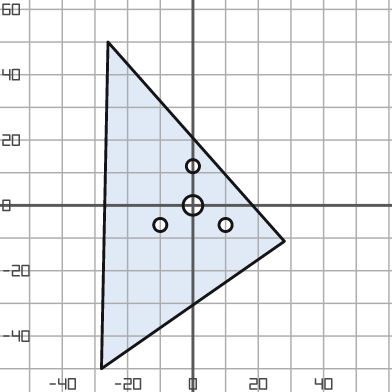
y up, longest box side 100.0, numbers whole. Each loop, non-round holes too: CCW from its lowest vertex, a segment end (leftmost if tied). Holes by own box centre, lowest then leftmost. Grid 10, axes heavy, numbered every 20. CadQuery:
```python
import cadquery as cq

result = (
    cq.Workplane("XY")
    .moveTo(-28.0, -50.0)
    .lineTo(28.0, -11.0)
    .lineTo(-26.0, 50.0)
    .close()
    .moveTo(-10.0, -6.0)
    .circle(2.0)
    .moveTo(10.0, -6.0)
    .circle(2.0)
    .moveTo(0.0, 0.0)
    .circle(3.0)
    .moveTo(0.0, 12.0)
    .circle(2.0)
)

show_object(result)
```